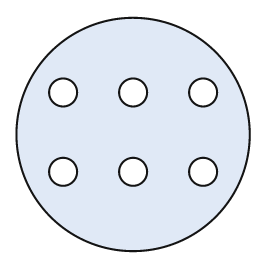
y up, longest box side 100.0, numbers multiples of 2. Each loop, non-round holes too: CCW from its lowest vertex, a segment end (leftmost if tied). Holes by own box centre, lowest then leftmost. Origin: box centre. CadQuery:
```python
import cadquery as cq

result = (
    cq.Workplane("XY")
    .moveTo(0.0, 0.0)
    .circle(50.0)
    .moveTo(-30.0, -16.0)
    .circle(6.0)
    .moveTo(0.0, -16.0)
    .circle(6.0)
    .moveTo(30.0, -16.0)
    .circle(6.0)
    .moveTo(-30.0, 18.0)
    .circle(6.0)
    .moveTo(0.0, 18.0)
    .circle(6.0)
    .moveTo(30.0, 18.0)
    .circle(6.0)
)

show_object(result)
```